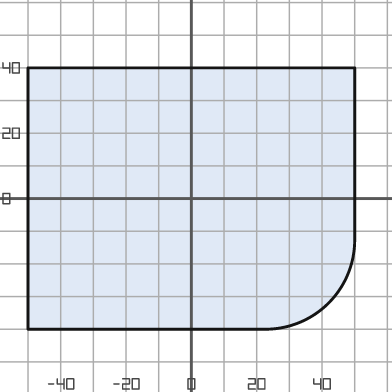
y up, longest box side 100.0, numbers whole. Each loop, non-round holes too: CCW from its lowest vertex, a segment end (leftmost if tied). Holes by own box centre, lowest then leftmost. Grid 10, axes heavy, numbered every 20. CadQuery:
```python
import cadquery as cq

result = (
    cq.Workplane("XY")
    .moveTo(-50.0, -40.0)
    .lineTo(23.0, -40.0)
    .threePointArc((42.0, -32.0), (50.0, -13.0))
    .lineTo(50.0, 40.0)
    .lineTo(-50.0, 40.0)
    .close()
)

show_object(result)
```